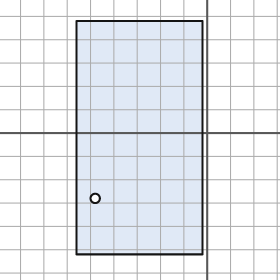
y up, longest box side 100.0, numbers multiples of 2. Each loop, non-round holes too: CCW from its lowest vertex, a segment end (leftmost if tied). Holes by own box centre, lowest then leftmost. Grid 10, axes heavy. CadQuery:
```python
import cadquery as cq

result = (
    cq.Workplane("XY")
    .moveTo(-56.0, -52.0)
    .lineTo(-2.0, -52.0)
    .lineTo(-2.0, 48.0)
    .lineTo(-56.0, 48.0)
    .close()
    .moveTo(-48.0, -28.0)
    .circle(2.0)
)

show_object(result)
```